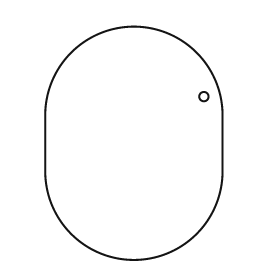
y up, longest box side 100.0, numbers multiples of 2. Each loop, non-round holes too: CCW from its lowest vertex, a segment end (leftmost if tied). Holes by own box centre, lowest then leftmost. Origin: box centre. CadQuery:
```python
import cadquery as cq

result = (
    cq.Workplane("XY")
    .moveTo(-38.0, -12.0)
    .threePointArc((0.0, -50.0), (38.0, -12.0))
    .lineTo(38.0, 12.0)
    .threePointArc((0.0, 50.0), (-38.0, 12.0))
    .close()
    .moveTo(30.0, 20.0)
    .circle(2.0)
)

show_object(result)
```